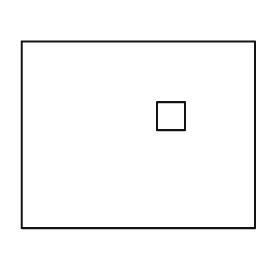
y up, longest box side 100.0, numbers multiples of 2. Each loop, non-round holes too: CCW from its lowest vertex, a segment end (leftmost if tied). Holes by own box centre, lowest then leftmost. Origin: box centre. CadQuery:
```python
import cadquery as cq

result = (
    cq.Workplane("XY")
    .moveTo(-50.0, -40.0)
    .lineTo(50.0, -40.0)
    .lineTo(50.0, 40.0)
    .lineTo(-50.0, 40.0)
    .close()
    .moveTo(8.0, 2.0)
    .lineTo(20.0, 2.0)
    .lineTo(20.0, 14.0)
    .lineTo(8.0, 14.0)
    .close()
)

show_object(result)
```